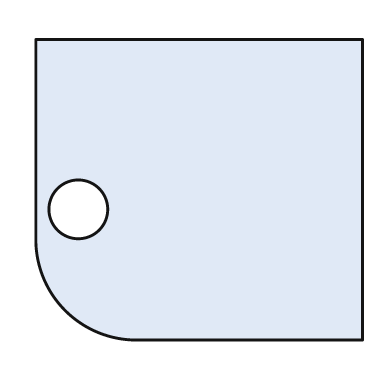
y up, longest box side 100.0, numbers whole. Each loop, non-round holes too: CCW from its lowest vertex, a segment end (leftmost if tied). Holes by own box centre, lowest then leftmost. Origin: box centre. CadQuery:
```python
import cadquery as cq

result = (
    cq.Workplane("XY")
    .moveTo(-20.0, -46.0)
    .lineTo(50.0, -46.0)
    .lineTo(50.0, 46.0)
    .lineTo(-50.0, 46.0)
    .lineTo(-50.0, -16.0)
    .threePointArc((-41.0, -37.0), (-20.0, -46.0))
    .close()
    .moveTo(-37.0, -6.0)
    .circle(9.0)
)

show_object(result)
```